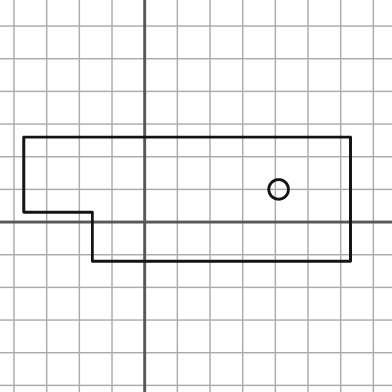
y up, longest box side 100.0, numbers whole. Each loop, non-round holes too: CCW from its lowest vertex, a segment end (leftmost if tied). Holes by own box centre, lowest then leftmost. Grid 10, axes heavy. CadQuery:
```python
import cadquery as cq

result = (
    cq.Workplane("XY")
    .moveTo(-16.0, -12.0)
    .lineTo(63.0, -12.0)
    .lineTo(63.0, 26.0)
    .lineTo(-37.0, 26.0)
    .lineTo(-37.0, 3.0)
    .lineTo(-16.0, 3.0)
    .close()
    .moveTo(41.0, 10.0)
    .circle(3.0)
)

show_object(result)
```